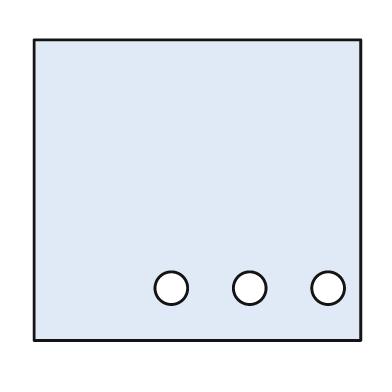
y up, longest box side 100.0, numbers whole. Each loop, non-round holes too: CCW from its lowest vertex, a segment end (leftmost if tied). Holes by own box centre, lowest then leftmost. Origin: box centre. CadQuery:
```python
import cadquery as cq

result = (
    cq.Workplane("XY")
    .moveTo(-50.0, -46.0)
    .lineTo(50.0, -46.0)
    .lineTo(50.0, 46.0)
    .lineTo(-50.0, 46.0)
    .close()
    .moveTo(-8.0, -30.0)
    .circle(5.0)
    .moveTo(16.0, -30.0)
    .circle(5.0)
    .moveTo(40.0, -30.0)
    .circle(5.0)
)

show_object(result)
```